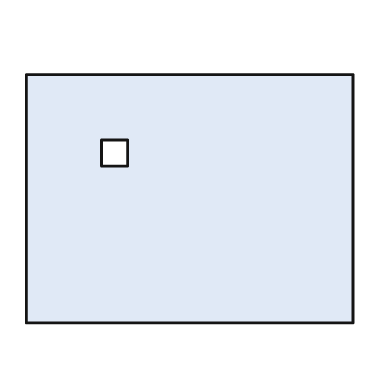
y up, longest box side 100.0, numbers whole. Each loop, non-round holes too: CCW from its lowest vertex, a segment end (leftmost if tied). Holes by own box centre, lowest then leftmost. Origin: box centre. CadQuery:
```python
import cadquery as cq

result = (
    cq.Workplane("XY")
    .moveTo(-50.0, -38.0)
    .lineTo(50.0, -38.0)
    .lineTo(50.0, 38.0)
    .lineTo(-50.0, 38.0)
    .close()
    .moveTo(-27.0, 10.0)
    .lineTo(-19.0, 10.0)
    .lineTo(-19.0, 18.0)
    .lineTo(-27.0, 18.0)
    .close()
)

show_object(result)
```